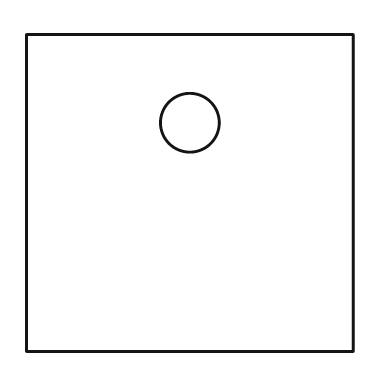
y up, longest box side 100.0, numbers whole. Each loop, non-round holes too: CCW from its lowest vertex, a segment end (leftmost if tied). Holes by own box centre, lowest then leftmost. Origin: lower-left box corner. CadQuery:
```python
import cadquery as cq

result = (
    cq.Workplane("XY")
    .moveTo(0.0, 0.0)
    .lineTo(100.0, 0.0)
    .lineTo(100.0, 97.0)
    .lineTo(0.0, 97.0)
    .close()
    .moveTo(50.0, 70.0)
    .circle(9.0)
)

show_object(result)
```